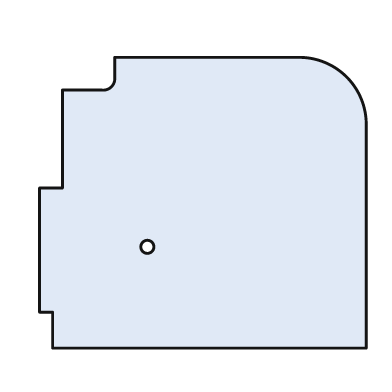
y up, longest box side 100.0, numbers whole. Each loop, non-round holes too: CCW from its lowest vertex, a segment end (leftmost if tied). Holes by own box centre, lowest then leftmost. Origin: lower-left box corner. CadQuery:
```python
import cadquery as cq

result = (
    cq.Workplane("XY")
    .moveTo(4.0, 0.0)
    .lineTo(100.0, 0.0)
    .lineTo(100.0, 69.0)
    .threePointArc((94.0, 83.0), (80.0, 89.0))
    .lineTo(23.0, 89.0)
    .lineTo(23.0, 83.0)
    .threePointArc((22.0, 80.0), (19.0, 79.0))
    .lineTo(7.0, 79.0)
    .lineTo(7.0, 49.0)
    .lineTo(0.0, 49.0)
    .lineTo(0.0, 11.0)
    .lineTo(4.0, 11.0)
    .close()
    .moveTo(33.0, 31.0)
    .circle(2.0)
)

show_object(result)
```